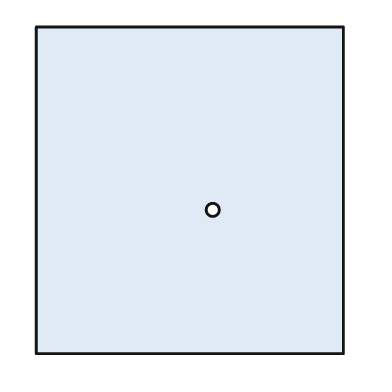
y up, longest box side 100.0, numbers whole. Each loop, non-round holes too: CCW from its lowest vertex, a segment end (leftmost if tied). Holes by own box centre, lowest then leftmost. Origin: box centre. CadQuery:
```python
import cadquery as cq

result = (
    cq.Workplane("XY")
    .moveTo(-47.0, -50.0)
    .lineTo(47.0, -50.0)
    .lineTo(47.0, 50.0)
    .lineTo(-47.0, 50.0)
    .close()
    .moveTo(7.0, -6.0)
    .circle(2.0)
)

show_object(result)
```